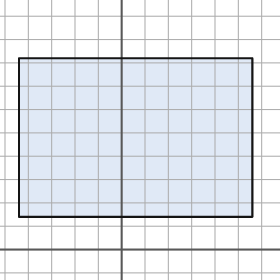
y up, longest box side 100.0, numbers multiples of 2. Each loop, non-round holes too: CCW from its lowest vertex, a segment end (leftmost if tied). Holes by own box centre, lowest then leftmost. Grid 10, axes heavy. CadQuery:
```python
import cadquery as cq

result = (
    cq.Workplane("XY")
    .moveTo(-44.0, 14.0)
    .lineTo(56.0, 14.0)
    .lineTo(56.0, 82.0)
    .lineTo(-44.0, 82.0)
    .close()
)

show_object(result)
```